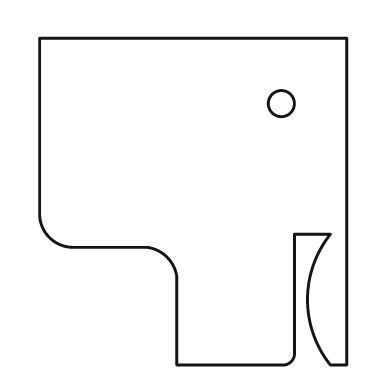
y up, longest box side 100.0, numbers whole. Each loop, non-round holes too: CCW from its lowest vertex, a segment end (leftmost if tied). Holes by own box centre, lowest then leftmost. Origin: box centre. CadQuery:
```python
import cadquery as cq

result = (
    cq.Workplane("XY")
    .moveTo(-5.0, -50.0)
    .lineTo(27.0, -50.0)
    .threePointArc((30.0, -49.0), (31.0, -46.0))
    .lineTo(31.0, -10.0)
    .lineTo(42.0, -10.0)
    .threePointArc((35.0, -30.0), (42.0, -50.0))
    .lineTo(47.0, -50.0)
    .lineTo(47.0, 50.0)
    .lineTo(-47.0, 50.0)
    .lineTo(-47.0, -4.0)
    .threePointArc((-44.0, -11.0), (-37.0, -14.0))
    .lineTo(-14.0, -14.0)
    .threePointArc((-8.0, -17.0), (-5.0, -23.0))
    .close()
    .moveTo(27.0, 30.0)
    .circle(4.0)
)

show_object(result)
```